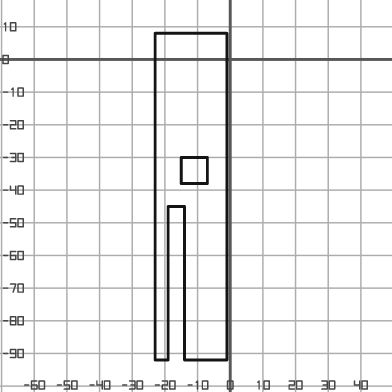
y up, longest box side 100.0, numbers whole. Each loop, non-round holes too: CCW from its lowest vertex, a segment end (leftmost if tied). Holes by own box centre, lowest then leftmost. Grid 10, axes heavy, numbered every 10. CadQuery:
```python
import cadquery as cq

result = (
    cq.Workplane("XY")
    .moveTo(-23.0, -92.0)
    .lineTo(-19.0, -92.0)
    .lineTo(-19.0, -45.0)
    .lineTo(-14.0, -45.0)
    .lineTo(-14.0, -92.0)
    .lineTo(-1.0, -92.0)
    .lineTo(-1.0, 8.0)
    .lineTo(-23.0, 8.0)
    .close()
    .moveTo(-15.0, -38.0)
    .lineTo(-7.0, -38.0)
    .lineTo(-7.0, -30.0)
    .lineTo(-15.0, -30.0)
    .close()
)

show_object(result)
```